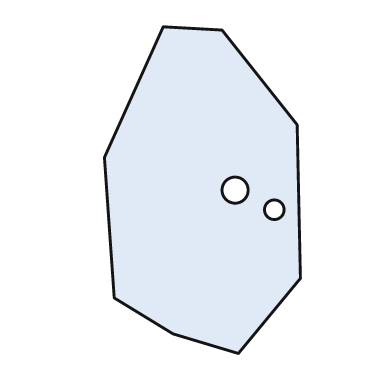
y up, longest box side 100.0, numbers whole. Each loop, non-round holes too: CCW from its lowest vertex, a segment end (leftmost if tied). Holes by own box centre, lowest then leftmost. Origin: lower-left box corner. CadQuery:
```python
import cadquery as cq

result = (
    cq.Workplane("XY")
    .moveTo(41.0, 0.0)
    .lineTo(60.0, 23.0)
    .lineTo(59.0, 70.0)
    .lineTo(36.0, 99.0)
    .lineTo(18.0, 100.0)
    .lineTo(0.0, 60.0)
    .lineTo(3.0, 17.0)
    .lineTo(21.0, 6.0)
    .close()
    .moveTo(52.0, 44.0)
    .circle(3.0)
    .moveTo(40.0, 50.0)
    .circle(4.0)
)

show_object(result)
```